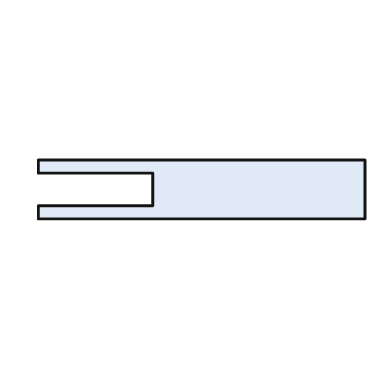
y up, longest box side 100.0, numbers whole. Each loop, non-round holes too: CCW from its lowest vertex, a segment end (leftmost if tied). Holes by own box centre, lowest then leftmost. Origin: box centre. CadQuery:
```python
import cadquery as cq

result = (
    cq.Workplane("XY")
    .moveTo(-50.0, -9.0)
    .lineTo(50.0, -9.0)
    .lineTo(50.0, 9.0)
    .lineTo(-50.0, 9.0)
    .lineTo(-50.0, 5.0)
    .lineTo(-15.0, 5.0)
    .lineTo(-15.0, -5.0)
    .lineTo(-50.0, -5.0)
    .close()
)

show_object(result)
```